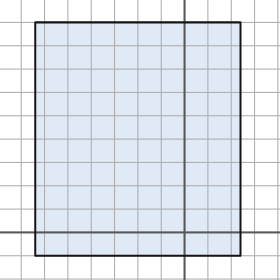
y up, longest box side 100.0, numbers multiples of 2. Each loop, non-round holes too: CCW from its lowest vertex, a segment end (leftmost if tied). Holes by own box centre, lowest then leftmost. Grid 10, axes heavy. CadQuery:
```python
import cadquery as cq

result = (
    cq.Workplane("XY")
    .moveTo(-64.0, -10.0)
    .lineTo(24.0, -10.0)
    .lineTo(24.0, 90.0)
    .lineTo(-64.0, 90.0)
    .close()
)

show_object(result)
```